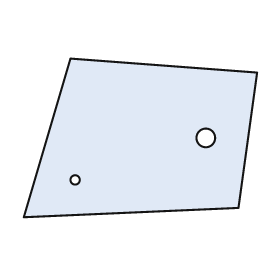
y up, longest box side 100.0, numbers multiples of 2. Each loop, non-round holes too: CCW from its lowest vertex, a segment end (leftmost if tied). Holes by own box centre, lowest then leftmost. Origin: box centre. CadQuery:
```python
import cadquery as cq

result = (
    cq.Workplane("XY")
    .moveTo(-50.0, -34.0)
    .lineTo(42.0, -30.0)
    .lineTo(50.0, 28.0)
    .lineTo(-30.0, 34.0)
    .close()
    .moveTo(-28.0, -18.0)
    .circle(2.0)
    .moveTo(28.0, 0.0)
    .circle(4.0)
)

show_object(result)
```